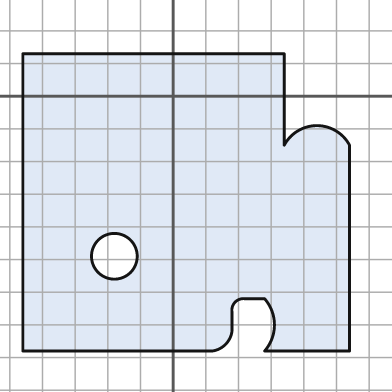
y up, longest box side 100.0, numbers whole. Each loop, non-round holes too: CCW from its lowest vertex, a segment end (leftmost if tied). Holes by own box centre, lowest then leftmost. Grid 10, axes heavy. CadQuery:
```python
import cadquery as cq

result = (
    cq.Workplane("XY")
    .moveTo(-46.0, -78.0)
    .lineTo(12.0, -78.0)
    .threePointArc((16.0, -76.0), (18.0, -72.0))
    .lineTo(18.0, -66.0)
    .threePointArc((19.0, -63.0), (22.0, -62.0))
    .lineTo(28.0, -62.0)
    .threePointArc((31.0, -70.0), (28.0, -78.0))
    .lineTo(54.0, -78.0)
    .lineTo(54.0, -15.0)
    .threePointArc((44.0, -9.0), (34.0, -15.0))
    .lineTo(34.0, 13.0)
    .lineTo(-46.0, 13.0)
    .close()
    .moveTo(-18.0, -49.0)
    .circle(7.0)
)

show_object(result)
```